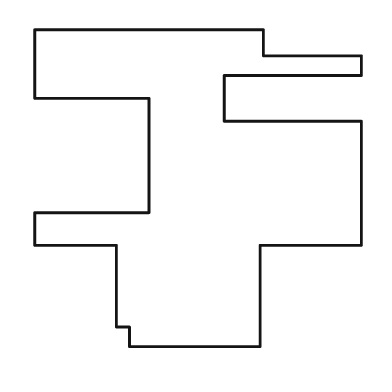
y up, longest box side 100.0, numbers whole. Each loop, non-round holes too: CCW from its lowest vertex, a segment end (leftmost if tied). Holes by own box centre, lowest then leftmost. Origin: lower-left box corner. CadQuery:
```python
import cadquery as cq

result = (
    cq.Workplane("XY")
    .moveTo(29.0, 0.0)
    .lineTo(69.0, 0.0)
    .lineTo(69.0, 31.0)
    .lineTo(100.0, 31.0)
    .lineTo(100.0, 69.0)
    .lineTo(58.0, 69.0)
    .lineTo(58.0, 83.0)
    .lineTo(100.0, 83.0)
    .lineTo(100.0, 89.0)
    .lineTo(70.0, 89.0)
    .lineTo(70.0, 97.0)
    .lineTo(0.0, 97.0)
    .lineTo(0.0, 76.0)
    .lineTo(35.0, 76.0)
    .lineTo(35.0, 41.0)
    .lineTo(0.0, 41.0)
    .lineTo(0.0, 31.0)
    .lineTo(25.0, 31.0)
    .lineTo(25.0, 6.0)
    .lineTo(29.0, 6.0)
    .close()
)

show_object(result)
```